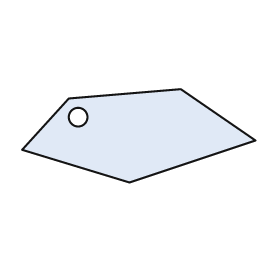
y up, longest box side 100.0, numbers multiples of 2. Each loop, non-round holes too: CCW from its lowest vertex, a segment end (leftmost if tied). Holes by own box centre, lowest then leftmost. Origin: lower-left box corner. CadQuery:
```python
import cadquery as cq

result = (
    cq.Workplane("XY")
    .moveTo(46.0, 0.0)
    .lineTo(100.0, 18.0)
    .lineTo(68.0, 40.0)
    .lineTo(20.0, 36.0)
    .lineTo(0.0, 14.0)
    .close()
    .moveTo(24.0, 28.0)
    .circle(4.0)
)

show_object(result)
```